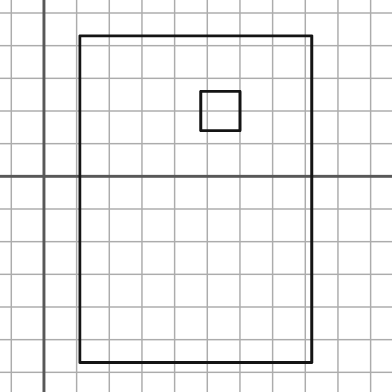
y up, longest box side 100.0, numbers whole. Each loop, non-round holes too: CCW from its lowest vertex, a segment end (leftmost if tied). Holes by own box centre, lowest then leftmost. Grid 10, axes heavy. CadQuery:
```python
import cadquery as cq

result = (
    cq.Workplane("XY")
    .moveTo(11.0, -57.0)
    .lineTo(82.0, -57.0)
    .lineTo(82.0, 43.0)
    .lineTo(11.0, 43.0)
    .close()
    .moveTo(48.0, 14.0)
    .lineTo(60.0, 14.0)
    .lineTo(60.0, 26.0)
    .lineTo(48.0, 26.0)
    .close()
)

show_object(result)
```